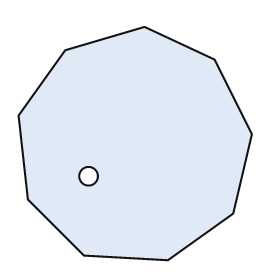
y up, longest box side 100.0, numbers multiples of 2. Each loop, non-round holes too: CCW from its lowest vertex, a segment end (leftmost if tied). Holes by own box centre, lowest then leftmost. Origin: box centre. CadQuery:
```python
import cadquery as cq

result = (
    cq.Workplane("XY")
    .moveTo(14.0, -50.0)
    .lineTo(42.0, -30.0)
    .lineTo(50.0, 4.0)
    .lineTo(34.0, 36.0)
    .lineTo(4.0, 50.0)
    .lineTo(-30.0, 40.0)
    .lineTo(-50.0, 12.0)
    .lineTo(-46.0, -24.0)
    .lineTo(-22.0, -48.0)
    .close()
    .moveTo(-20.0, -14.0)
    .circle(4.0)
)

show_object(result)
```